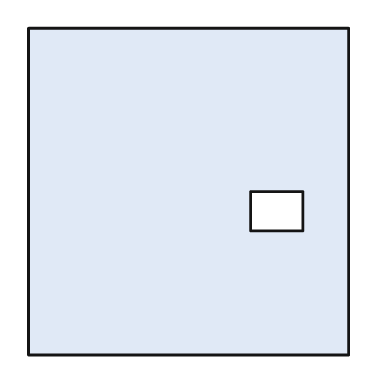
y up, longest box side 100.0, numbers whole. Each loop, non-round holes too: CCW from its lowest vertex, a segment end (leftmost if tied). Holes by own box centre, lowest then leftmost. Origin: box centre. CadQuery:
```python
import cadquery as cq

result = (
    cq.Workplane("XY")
    .moveTo(-49.0, -50.0)
    .lineTo(49.0, -50.0)
    .lineTo(49.0, 50.0)
    .lineTo(-49.0, 50.0)
    .close()
    .moveTo(19.0, -12.0)
    .lineTo(35.0, -12.0)
    .lineTo(35.0, 0.0)
    .lineTo(19.0, 0.0)
    .close()
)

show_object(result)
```